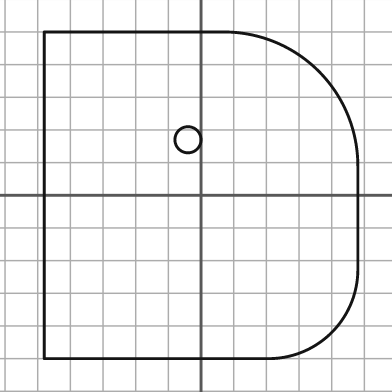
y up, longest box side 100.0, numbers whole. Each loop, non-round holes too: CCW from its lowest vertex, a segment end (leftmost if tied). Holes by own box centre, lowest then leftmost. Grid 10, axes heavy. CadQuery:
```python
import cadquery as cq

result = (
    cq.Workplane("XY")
    .moveTo(-48.0, -50.0)
    .lineTo(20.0, -50.0)
    .threePointArc((40.0, -42.0), (48.0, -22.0))
    .lineTo(48.0, 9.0)
    .threePointArc((36.0, 38.0), (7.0, 50.0))
    .lineTo(-48.0, 50.0)
    .close()
    .moveTo(-4.0, 17.0)
    .circle(4.0)
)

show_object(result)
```